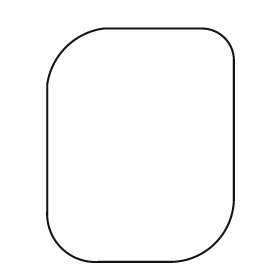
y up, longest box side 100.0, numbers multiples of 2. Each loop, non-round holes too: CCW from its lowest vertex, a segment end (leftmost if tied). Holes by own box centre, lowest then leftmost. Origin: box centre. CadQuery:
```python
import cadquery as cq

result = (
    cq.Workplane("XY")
    .moveTo(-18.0, -50.0)
    .lineTo(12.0, -50.0)
    .threePointArc((32.0, -42.0), (40.0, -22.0))
    .lineTo(40.0, 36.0)
    .threePointArc((36.0, 46.0), (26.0, 50.0))
    .lineTo(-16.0, 50.0)
    .threePointArc((-32.0, 42.0), (-40.0, 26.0))
    .lineTo(-40.0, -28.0)
    .threePointArc((-34.0, -44.0), (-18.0, -50.0))
    .close()
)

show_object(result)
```